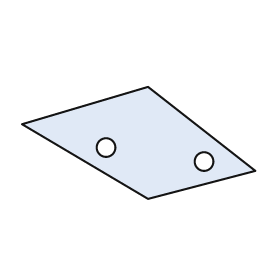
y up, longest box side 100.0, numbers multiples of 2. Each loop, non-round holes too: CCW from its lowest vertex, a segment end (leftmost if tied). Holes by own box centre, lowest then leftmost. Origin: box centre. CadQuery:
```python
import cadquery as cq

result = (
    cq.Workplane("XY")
    .moveTo(4.0, -24.0)
    .lineTo(50.0, -12.0)
    .lineTo(4.0, 24.0)
    .lineTo(-50.0, 8.0)
    .close()
    .moveTo(28.0, -8.0)
    .circle(4.0)
    .moveTo(-14.0, -2.0)
    .circle(4.0)
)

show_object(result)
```